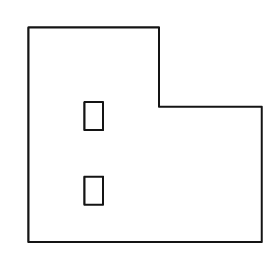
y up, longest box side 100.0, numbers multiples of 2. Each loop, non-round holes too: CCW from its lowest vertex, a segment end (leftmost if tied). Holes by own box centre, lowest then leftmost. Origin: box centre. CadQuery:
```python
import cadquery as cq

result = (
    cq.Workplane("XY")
    .moveTo(-50.0, -46.0)
    .lineTo(50.0, -46.0)
    .lineTo(50.0, 12.0)
    .lineTo(6.0, 12.0)
    .lineTo(6.0, 46.0)
    .lineTo(-50.0, 46.0)
    .close()
    .moveTo(-26.0, -30.0)
    .lineTo(-18.0, -30.0)
    .lineTo(-18.0, -18.0)
    .lineTo(-26.0, -18.0)
    .close()
    .moveTo(-26.0, 2.0)
    .lineTo(-18.0, 2.0)
    .lineTo(-18.0, 14.0)
    .lineTo(-26.0, 14.0)
    .close()
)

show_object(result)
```